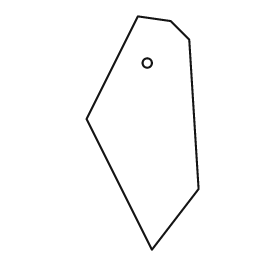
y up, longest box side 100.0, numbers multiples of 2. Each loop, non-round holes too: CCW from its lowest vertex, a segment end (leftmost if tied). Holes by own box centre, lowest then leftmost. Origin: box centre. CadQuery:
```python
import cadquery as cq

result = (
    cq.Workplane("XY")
    .moveTo(4.0, -50.0)
    .lineTo(24.0, -24.0)
    .lineTo(20.0, 40.0)
    .lineTo(12.0, 48.0)
    .lineTo(-2.0, 50.0)
    .lineTo(-24.0, 6.0)
    .close()
    .moveTo(2.0, 30.0)
    .circle(2.0)
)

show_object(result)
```